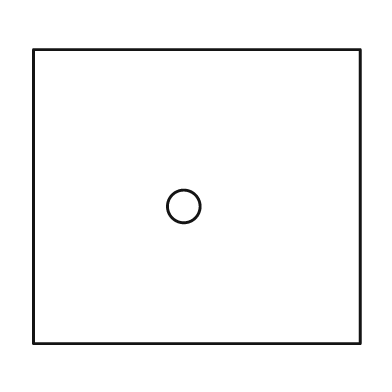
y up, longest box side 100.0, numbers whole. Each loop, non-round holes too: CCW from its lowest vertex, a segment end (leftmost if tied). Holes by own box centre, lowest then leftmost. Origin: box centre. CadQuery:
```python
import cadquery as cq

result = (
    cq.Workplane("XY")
    .moveTo(-50.0, -45.0)
    .lineTo(50.0, -45.0)
    .lineTo(50.0, 45.0)
    .lineTo(-50.0, 45.0)
    .close()
    .moveTo(-4.0, -3.0)
    .circle(5.0)
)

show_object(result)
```